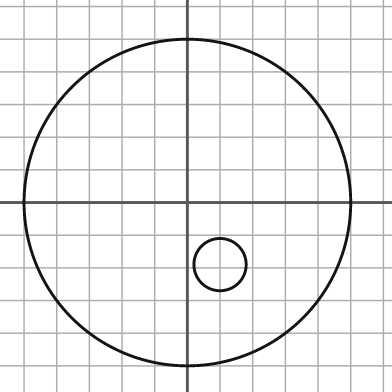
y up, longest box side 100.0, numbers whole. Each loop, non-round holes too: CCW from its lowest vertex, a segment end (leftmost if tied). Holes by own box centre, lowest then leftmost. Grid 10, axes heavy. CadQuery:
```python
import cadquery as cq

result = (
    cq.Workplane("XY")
    .moveTo(0.0, 0.0)
    .circle(50.0)
    .moveTo(10.0, -19.0)
    .circle(8.0)
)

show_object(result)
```